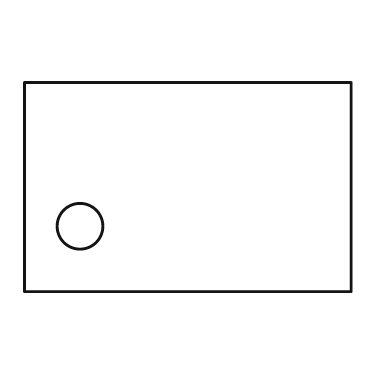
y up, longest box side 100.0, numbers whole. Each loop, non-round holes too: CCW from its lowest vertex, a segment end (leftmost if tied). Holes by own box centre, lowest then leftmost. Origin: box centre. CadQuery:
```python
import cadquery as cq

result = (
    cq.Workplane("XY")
    .moveTo(-50.0, -32.0)
    .lineTo(50.0, -32.0)
    .lineTo(50.0, 32.0)
    .lineTo(-50.0, 32.0)
    .close()
    .moveTo(-33.0, -12.0)
    .circle(7.0)
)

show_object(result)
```